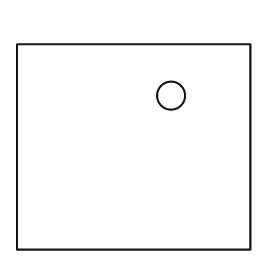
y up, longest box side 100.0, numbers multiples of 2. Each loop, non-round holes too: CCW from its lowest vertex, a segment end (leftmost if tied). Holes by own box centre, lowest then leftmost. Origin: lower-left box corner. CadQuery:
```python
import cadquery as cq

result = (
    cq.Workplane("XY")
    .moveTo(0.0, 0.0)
    .lineTo(100.0, 0.0)
    .lineTo(100.0, 88.0)
    .lineTo(0.0, 88.0)
    .close()
    .moveTo(66.0, 66.0)
    .circle(6.0)
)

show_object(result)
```